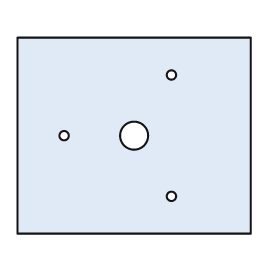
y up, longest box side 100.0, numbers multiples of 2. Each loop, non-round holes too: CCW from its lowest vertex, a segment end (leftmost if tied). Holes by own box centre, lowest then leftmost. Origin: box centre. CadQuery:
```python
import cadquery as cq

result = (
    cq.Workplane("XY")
    .moveTo(-50.0, -42.0)
    .lineTo(50.0, -42.0)
    .lineTo(50.0, 42.0)
    .lineTo(-50.0, 42.0)
    .close()
    .moveTo(16.0, -26.0)
    .circle(2.0)
    .moveTo(-30.0, 0.0)
    .circle(2.0)
    .moveTo(0.0, 0.0)
    .circle(6.0)
    .moveTo(16.0, 26.0)
    .circle(2.0)
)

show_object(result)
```